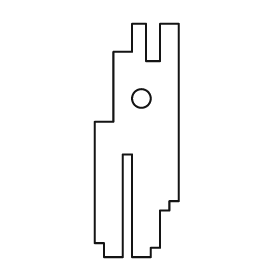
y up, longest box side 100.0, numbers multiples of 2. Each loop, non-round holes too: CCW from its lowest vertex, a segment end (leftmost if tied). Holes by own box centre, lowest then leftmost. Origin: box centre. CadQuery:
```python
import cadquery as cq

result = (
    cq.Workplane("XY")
    .moveTo(-14.0, -50.0)
    .lineTo(-6.0, -50.0)
    .lineTo(-6.0, -6.0)
    .lineTo(-2.0, -6.0)
    .lineTo(-2.0, -50.0)
    .lineTo(6.0, -50.0)
    .lineTo(6.0, -46.0)
    .lineTo(10.0, -46.0)
    .lineTo(10.0, -30.0)
    .lineTo(14.0, -30.0)
    .lineTo(14.0, -26.0)
    .lineTo(18.0, -26.0)
    .lineTo(18.0, 50.0)
    .lineTo(10.0, 50.0)
    .lineTo(10.0, 34.0)
    .lineTo(4.0, 34.0)
    .lineTo(4.0, 50.0)
    .lineTo(-2.0, 50.0)
    .lineTo(-2.0, 38.0)
    .lineTo(-10.0, 38.0)
    .lineTo(-10.0, 8.0)
    .lineTo(-18.0, 8.0)
    .lineTo(-18.0, -44.0)
    .lineTo(-14.0, -44.0)
    .close()
    .moveTo(2.0, 18.0)
    .circle(4.0)
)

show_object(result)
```